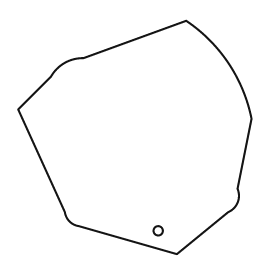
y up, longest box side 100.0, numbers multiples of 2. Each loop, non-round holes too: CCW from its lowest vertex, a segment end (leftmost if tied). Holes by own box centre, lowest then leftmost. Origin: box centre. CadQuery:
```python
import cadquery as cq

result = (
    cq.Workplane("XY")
    .moveTo(18.0, -50.0)
    .lineTo(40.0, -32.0)
    .threePointArc((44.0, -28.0), (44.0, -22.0))
    .lineTo(50.0, 8.0)
    .threePointArc((40.0, 32.0), (22.0, 50.0))
    .lineTo(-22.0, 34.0)
    .threePointArc((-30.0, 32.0), (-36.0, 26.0))
    .lineTo(-50.0, 12.0)
    .lineTo(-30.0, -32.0)
    .threePointArc((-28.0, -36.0), (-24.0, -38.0))
    .close()
    .moveTo(10.0, -40.0)
    .circle(2.0)
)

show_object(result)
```